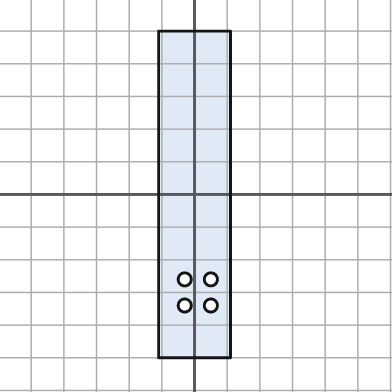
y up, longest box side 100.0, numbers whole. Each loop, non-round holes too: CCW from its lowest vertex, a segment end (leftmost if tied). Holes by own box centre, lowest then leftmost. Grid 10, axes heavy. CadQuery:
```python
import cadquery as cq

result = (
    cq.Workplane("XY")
    .moveTo(-11.0, -50.0)
    .lineTo(11.0, -50.0)
    .lineTo(11.0, 50.0)
    .lineTo(-11.0, 50.0)
    .close()
    .moveTo(-3.0, -34.0)
    .circle(2.0)
    .moveTo(5.0, -34.0)
    .circle(2.0)
    .moveTo(-3.0, -26.0)
    .circle(2.0)
    .moveTo(5.0, -26.0)
    .circle(2.0)
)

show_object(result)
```